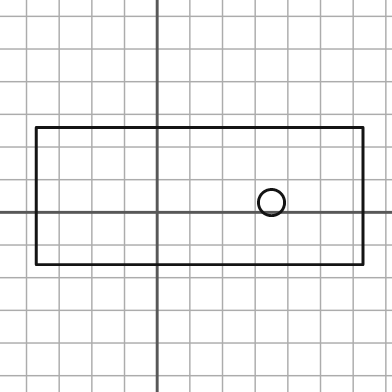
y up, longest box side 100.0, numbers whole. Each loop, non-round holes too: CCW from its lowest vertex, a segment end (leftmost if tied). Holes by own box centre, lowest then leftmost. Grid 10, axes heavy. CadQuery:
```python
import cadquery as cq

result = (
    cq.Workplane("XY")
    .moveTo(-37.0, -16.0)
    .lineTo(63.0, -16.0)
    .lineTo(63.0, 26.0)
    .lineTo(-37.0, 26.0)
    .close()
    .moveTo(35.0, 3.0)
    .circle(4.0)
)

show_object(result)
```